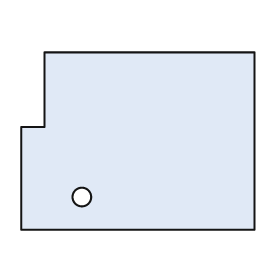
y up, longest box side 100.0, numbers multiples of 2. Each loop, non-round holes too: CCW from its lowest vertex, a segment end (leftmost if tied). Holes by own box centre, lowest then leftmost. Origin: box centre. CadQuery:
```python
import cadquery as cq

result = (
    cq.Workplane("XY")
    .moveTo(-50.0, -38.0)
    .lineTo(50.0, -38.0)
    .lineTo(50.0, 38.0)
    .lineTo(-40.0, 38.0)
    .lineTo(-40.0, 6.0)
    .lineTo(-50.0, 6.0)
    .close()
    .moveTo(-24.0, -24.0)
    .circle(4.0)
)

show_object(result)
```